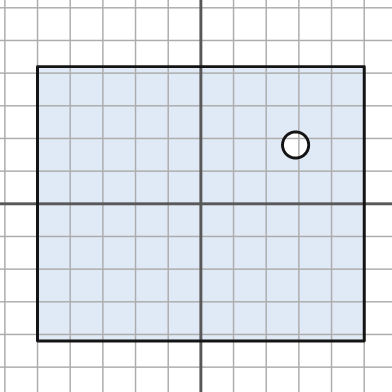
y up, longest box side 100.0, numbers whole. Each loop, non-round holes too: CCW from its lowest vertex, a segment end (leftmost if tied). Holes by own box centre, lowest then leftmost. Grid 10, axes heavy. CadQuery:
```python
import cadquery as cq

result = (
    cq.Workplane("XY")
    .moveTo(-50.0, -42.0)
    .lineTo(50.0, -42.0)
    .lineTo(50.0, 42.0)
    .lineTo(-50.0, 42.0)
    .close()
    .moveTo(29.0, 18.0)
    .circle(4.0)
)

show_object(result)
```